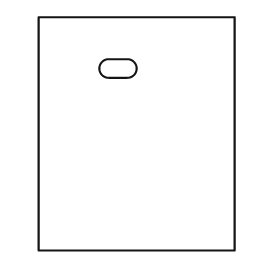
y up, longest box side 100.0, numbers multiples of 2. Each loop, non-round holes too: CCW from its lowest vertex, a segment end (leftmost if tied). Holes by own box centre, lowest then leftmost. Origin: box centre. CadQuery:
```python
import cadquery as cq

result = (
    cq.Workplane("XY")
    .moveTo(-42.0, -50.0)
    .lineTo(42.0, -50.0)
    .lineTo(42.0, 50.0)
    .lineTo(-42.0, 50.0)
    .close()
    .moveTo(-12.0, 24.0)
    .lineTo(-4.0, 24.0)
    .threePointArc((0.0, 28.0), (-4.0, 32.0))
    .lineTo(-12.0, 32.0)
    .threePointArc((-16.0, 28.0), (-12.0, 24.0))
    .close()
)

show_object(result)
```